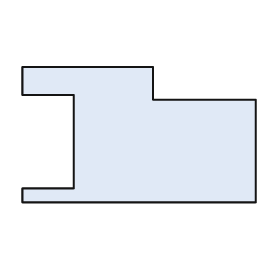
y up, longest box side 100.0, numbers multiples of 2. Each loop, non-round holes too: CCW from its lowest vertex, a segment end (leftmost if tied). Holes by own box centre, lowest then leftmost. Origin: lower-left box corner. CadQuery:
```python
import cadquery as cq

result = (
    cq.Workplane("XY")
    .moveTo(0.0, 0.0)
    .lineTo(100.0, 0.0)
    .lineTo(100.0, 44.0)
    .lineTo(56.0, 44.0)
    .lineTo(56.0, 58.0)
    .lineTo(0.0, 58.0)
    .lineTo(0.0, 46.0)
    .lineTo(22.0, 46.0)
    .lineTo(22.0, 6.0)
    .lineTo(0.0, 6.0)
    .close()
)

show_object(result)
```